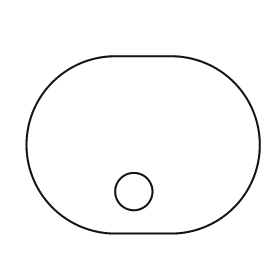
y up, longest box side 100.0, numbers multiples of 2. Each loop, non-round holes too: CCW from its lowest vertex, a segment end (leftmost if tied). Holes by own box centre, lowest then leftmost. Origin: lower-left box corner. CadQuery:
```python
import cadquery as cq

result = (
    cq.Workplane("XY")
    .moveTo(38.0, 0.0)
    .lineTo(62.0, 0.0)
    .threePointArc((100.0, 38.0), (62.0, 76.0))
    .lineTo(38.0, 76.0)
    .threePointArc((0.0, 38.0), (38.0, 0.0))
    .close()
    .moveTo(46.0, 18.0)
    .circle(8.0)
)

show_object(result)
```